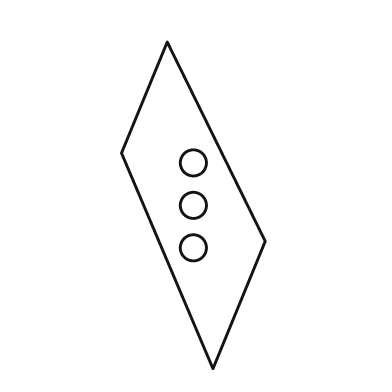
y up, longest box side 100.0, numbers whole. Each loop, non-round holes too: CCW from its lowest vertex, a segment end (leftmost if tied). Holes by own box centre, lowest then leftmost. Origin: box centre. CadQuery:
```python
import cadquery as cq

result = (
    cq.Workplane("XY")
    .moveTo(6.0, -50.0)
    .lineTo(22.0, -11.0)
    .lineTo(-8.0, 50.0)
    .lineTo(-22.0, 16.0)
    .close()
    .moveTo(0.0, -13.0)
    .circle(4.0)
    .moveTo(0.0, 0.0)
    .circle(4.0)
    .moveTo(0.0, 13.0)
    .circle(4.0)
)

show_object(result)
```